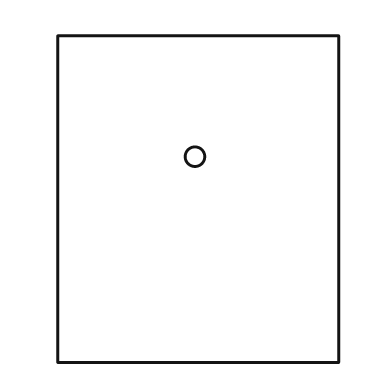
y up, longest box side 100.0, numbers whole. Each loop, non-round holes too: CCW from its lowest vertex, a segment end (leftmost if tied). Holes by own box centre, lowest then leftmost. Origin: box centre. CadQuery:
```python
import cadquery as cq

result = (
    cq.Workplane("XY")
    .moveTo(-43.0, -50.0)
    .lineTo(43.0, -50.0)
    .lineTo(43.0, 50.0)
    .lineTo(-43.0, 50.0)
    .close()
    .moveTo(-1.0, 13.0)
    .circle(3.0)
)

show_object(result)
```